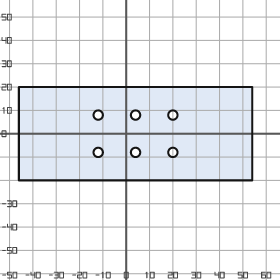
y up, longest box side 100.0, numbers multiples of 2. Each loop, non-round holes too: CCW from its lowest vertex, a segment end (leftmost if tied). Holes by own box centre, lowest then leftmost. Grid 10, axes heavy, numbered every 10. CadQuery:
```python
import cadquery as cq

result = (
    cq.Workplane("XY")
    .moveTo(-46.0, -20.0)
    .lineTo(54.0, -20.0)
    .lineTo(54.0, 20.0)
    .lineTo(-46.0, 20.0)
    .close()
    .moveTo(-12.0, -8.0)
    .circle(2.0)
    .moveTo(4.0, -8.0)
    .circle(2.0)
    .moveTo(20.0, -8.0)
    .circle(2.0)
    .moveTo(-12.0, 8.0)
    .circle(2.0)
    .moveTo(4.0, 8.0)
    .circle(2.0)
    .moveTo(20.0, 8.0)
    .circle(2.0)
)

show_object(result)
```